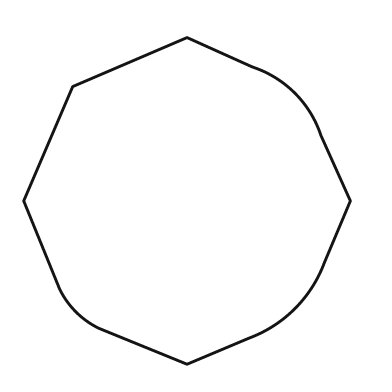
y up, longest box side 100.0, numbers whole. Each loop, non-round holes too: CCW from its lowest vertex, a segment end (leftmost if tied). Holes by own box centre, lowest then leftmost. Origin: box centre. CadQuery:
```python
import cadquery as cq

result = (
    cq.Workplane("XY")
    .moveTo(0.0, -50.0)
    .lineTo(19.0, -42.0)
    .threePointArc((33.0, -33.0), (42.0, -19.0))
    .lineTo(50.0, 0.0)
    .lineTo(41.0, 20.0)
    .threePointArc((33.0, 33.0), (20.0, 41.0))
    .lineTo(0.0, 50.0)
    .lineTo(-35.0, 35.0)
    .lineTo(-50.0, 0.0)
    .lineTo(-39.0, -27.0)
    .threePointArc((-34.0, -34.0), (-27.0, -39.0))
    .close()
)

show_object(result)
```